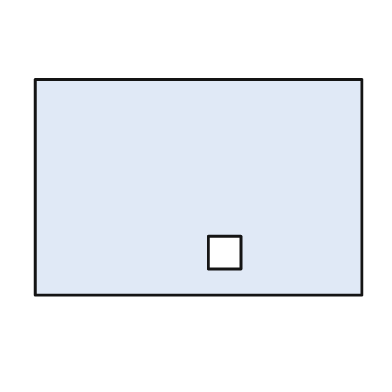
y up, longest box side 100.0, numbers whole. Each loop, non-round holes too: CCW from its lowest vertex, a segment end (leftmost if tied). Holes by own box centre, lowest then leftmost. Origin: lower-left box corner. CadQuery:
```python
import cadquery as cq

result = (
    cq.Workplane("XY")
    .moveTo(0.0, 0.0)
    .lineTo(100.0, 0.0)
    .lineTo(100.0, 66.0)
    .lineTo(0.0, 66.0)
    .close()
    .moveTo(53.0, 8.0)
    .lineTo(63.0, 8.0)
    .lineTo(63.0, 18.0)
    .lineTo(53.0, 18.0)
    .close()
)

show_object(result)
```